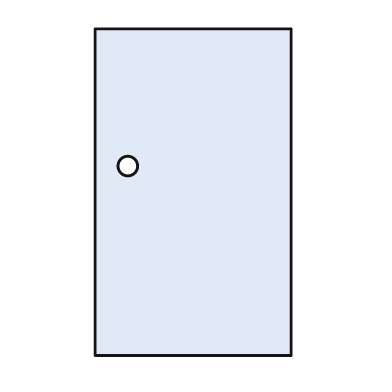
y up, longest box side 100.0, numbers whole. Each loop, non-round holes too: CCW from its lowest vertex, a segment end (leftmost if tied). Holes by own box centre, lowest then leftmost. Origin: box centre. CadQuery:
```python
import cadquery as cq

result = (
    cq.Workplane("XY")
    .moveTo(-30.0, -50.0)
    .lineTo(30.0, -50.0)
    .lineTo(30.0, 50.0)
    .lineTo(-30.0, 50.0)
    .close()
    .moveTo(-20.0, 8.0)
    .circle(3.0)
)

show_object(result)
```